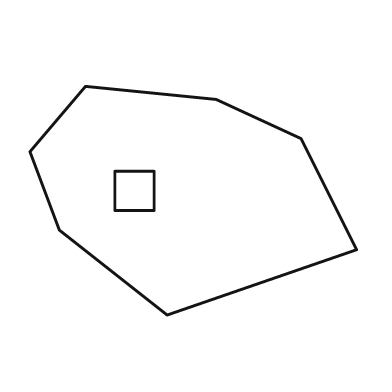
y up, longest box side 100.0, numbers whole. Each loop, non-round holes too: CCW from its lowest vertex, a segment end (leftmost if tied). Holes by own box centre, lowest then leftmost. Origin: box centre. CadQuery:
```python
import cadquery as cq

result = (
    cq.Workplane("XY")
    .moveTo(-8.0, -35.0)
    .lineTo(50.0, -15.0)
    .lineTo(33.0, 19.0)
    .lineTo(7.0, 31.0)
    .lineTo(-33.0, 35.0)
    .lineTo(-50.0, 15.0)
    .lineTo(-41.0, -9.0)
    .close()
    .moveTo(-24.0, -3.0)
    .lineTo(-12.0, -3.0)
    .lineTo(-12.0, 9.0)
    .lineTo(-24.0, 9.0)
    .close()
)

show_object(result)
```